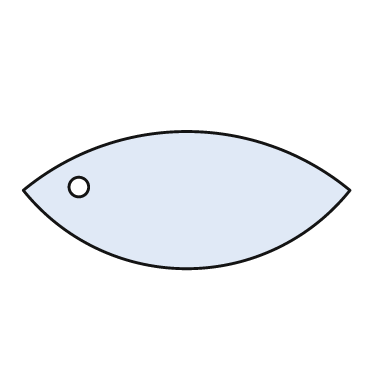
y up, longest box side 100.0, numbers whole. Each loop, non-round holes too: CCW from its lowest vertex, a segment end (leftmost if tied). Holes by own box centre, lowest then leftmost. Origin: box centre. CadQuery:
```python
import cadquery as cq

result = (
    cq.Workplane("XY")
    .moveTo(-50.0, 3.0)
    .threePointArc((0.0, -21.0), (50.0, 3.0))
    .threePointArc((0.0, 21.0), (-50.0, 3.0))
    .close()
    .moveTo(-33.0, 4.0)
    .circle(3.0)
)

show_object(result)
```